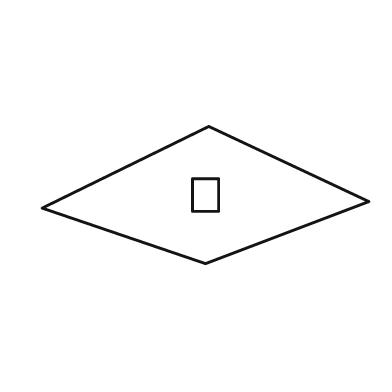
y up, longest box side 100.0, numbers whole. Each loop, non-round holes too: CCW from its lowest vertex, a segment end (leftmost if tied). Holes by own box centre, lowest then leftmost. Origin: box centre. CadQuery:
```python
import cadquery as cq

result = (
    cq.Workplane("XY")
    .moveTo(0.0, -21.0)
    .lineTo(50.0, -2.0)
    .lineTo(1.0, 21.0)
    .lineTo(-50.0, -4.0)
    .close()
    .moveTo(-4.0, -5.0)
    .lineTo(4.0, -5.0)
    .lineTo(4.0, 5.0)
    .lineTo(-4.0, 5.0)
    .close()
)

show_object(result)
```